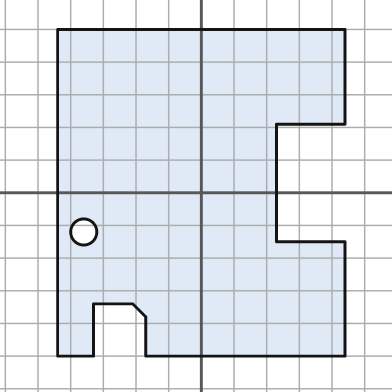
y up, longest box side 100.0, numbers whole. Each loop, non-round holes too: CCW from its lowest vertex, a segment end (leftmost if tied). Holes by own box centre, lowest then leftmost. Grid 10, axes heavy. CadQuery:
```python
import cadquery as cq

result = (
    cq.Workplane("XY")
    .moveTo(-44.0, -50.0)
    .lineTo(-33.0, -50.0)
    .lineTo(-33.0, -34.0)
    .lineTo(-21.0, -34.0)
    .lineTo(-17.0, -38.0)
    .lineTo(-17.0, -50.0)
    .lineTo(44.0, -50.0)
    .lineTo(44.0, -15.0)
    .lineTo(23.0, -15.0)
    .lineTo(23.0, 21.0)
    .lineTo(44.0, 21.0)
    .lineTo(44.0, 50.0)
    .lineTo(-44.0, 50.0)
    .close()
    .moveTo(-36.0, -12.0)
    .circle(4.0)
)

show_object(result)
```